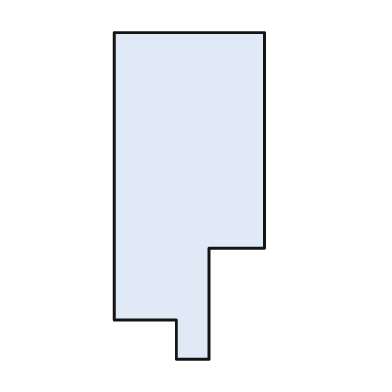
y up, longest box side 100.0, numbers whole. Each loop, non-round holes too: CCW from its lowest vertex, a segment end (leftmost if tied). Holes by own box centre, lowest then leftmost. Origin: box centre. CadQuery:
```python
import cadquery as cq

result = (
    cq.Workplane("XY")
    .moveTo(-4.0, -50.0)
    .lineTo(6.0, -50.0)
    .lineTo(6.0, -16.0)
    .lineTo(23.0, -16.0)
    .lineTo(23.0, 50.0)
    .lineTo(-23.0, 50.0)
    .lineTo(-23.0, -38.0)
    .lineTo(-4.0, -38.0)
    .close()
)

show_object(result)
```